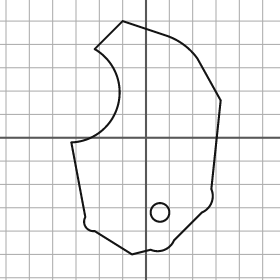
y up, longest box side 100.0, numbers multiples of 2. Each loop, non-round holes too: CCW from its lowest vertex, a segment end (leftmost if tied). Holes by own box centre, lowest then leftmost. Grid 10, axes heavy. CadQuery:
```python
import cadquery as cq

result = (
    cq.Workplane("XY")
    .moveTo(-6.0, -50.0)
    .lineTo(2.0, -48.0)
    .threePointArc((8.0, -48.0), (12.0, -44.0))
    .lineTo(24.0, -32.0)
    .threePointArc((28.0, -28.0), (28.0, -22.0))
    .lineTo(32.0, 16.0)
    .lineTo(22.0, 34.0)
    .threePointArc((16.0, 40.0), (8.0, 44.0))
    .lineTo(-10.0, 50.0)
    .lineTo(-22.0, 38.0)
    .threePointArc((-12.0, 14.0), (-32.0, -2.0))
    .lineTo(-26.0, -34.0)
    .threePointArc((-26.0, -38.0), (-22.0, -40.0))
    .close()
    .moveTo(6.0, -32.0)
    .circle(4.0)
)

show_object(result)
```